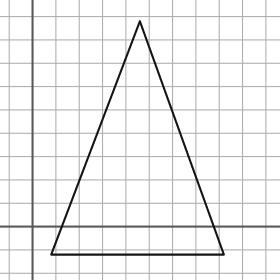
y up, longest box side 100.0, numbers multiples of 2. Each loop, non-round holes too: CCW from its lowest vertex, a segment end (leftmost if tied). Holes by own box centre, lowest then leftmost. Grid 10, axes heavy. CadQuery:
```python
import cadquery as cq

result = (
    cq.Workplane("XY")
    .moveTo(8.0, -12.0)
    .lineTo(82.0, -12.0)
    .lineTo(46.0, 88.0)
    .close()
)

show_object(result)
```